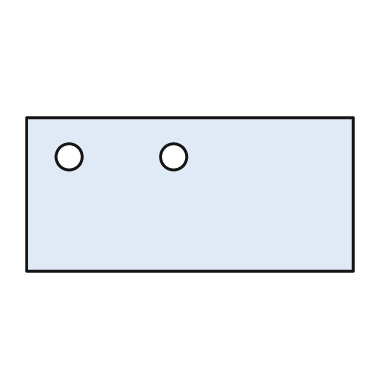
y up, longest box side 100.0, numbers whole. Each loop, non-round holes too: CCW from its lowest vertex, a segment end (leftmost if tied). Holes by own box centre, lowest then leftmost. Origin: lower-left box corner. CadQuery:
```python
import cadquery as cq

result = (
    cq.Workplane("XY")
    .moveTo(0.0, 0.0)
    .lineTo(100.0, 0.0)
    .lineTo(100.0, 47.0)
    .lineTo(0.0, 47.0)
    .close()
    .moveTo(13.0, 35.0)
    .circle(4.0)
    .moveTo(45.0, 35.0)
    .circle(4.0)
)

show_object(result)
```